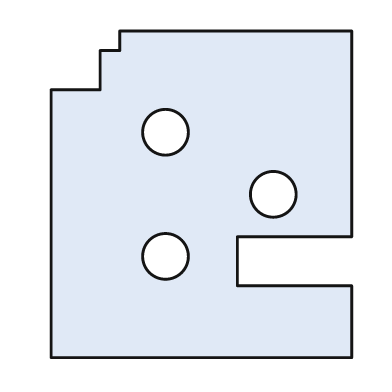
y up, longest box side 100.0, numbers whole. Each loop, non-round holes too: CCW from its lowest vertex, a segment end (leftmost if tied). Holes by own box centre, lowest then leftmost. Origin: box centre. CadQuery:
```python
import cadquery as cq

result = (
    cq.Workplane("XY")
    .moveTo(-46.0, -50.0)
    .lineTo(46.0, -50.0)
    .lineTo(46.0, -28.0)
    .lineTo(11.0, -28.0)
    .lineTo(11.0, -13.0)
    .lineTo(46.0, -13.0)
    .lineTo(46.0, 50.0)
    .lineTo(-25.0, 50.0)
    .lineTo(-25.0, 44.0)
    .lineTo(-31.0, 44.0)
    .lineTo(-31.0, 32.0)
    .lineTo(-46.0, 32.0)
    .close()
    .moveTo(-11.0, -19.0)
    .circle(7.0)
    .moveTo(22.0, 0.0)
    .circle(7.0)
    .moveTo(-11.0, 19.0)
    .circle(7.0)
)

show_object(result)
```